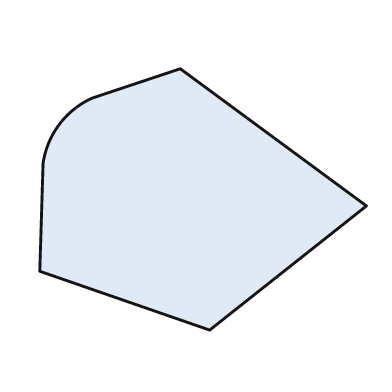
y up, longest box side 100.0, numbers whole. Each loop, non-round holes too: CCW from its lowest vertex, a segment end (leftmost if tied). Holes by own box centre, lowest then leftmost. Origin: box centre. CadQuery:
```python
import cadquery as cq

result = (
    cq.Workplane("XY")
    .moveTo(2.0, -40.0)
    .lineTo(50.0, -2.0)
    .lineTo(-7.0, 40.0)
    .lineTo(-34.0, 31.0)
    .threePointArc((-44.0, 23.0), (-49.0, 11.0))
    .lineTo(-50.0, -22.0)
    .close()
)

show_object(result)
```